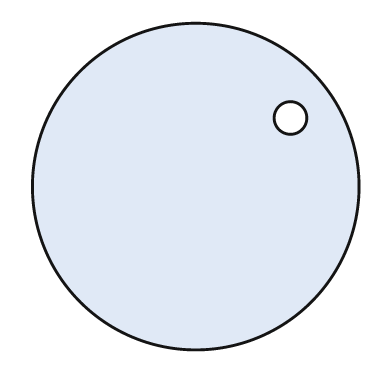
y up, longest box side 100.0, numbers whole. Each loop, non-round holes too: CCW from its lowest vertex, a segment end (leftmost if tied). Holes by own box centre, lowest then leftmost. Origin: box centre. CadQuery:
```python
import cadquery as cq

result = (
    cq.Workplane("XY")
    .moveTo(0.0, 0.0)
    .circle(50.0)
    .moveTo(29.0, 21.0)
    .circle(5.0)
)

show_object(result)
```